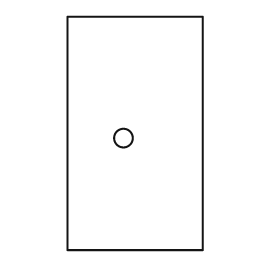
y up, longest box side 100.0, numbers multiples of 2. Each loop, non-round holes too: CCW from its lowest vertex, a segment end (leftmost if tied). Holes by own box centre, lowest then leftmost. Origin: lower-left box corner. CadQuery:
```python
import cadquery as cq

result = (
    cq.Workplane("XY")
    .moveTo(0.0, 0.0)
    .lineTo(58.0, 0.0)
    .lineTo(58.0, 100.0)
    .lineTo(0.0, 100.0)
    .close()
    .moveTo(24.0, 48.0)
    .circle(4.0)
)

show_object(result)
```